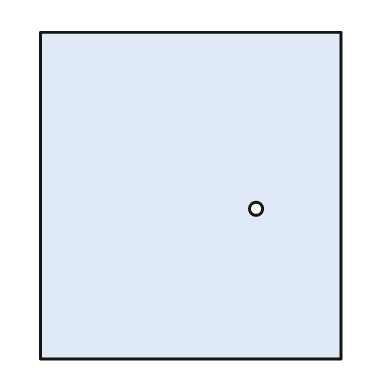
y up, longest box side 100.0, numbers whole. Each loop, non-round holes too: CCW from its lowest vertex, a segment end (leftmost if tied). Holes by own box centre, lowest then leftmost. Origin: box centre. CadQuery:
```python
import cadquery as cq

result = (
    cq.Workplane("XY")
    .moveTo(-46.0, -50.0)
    .lineTo(46.0, -50.0)
    .lineTo(46.0, 50.0)
    .lineTo(-46.0, 50.0)
    .close()
    .moveTo(20.0, -4.0)
    .circle(2.0)
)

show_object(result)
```